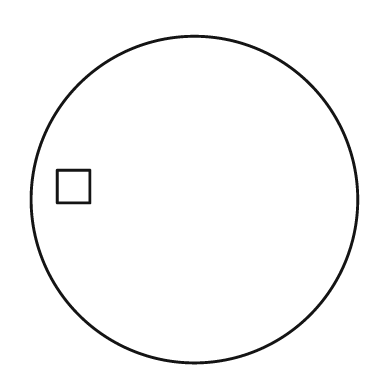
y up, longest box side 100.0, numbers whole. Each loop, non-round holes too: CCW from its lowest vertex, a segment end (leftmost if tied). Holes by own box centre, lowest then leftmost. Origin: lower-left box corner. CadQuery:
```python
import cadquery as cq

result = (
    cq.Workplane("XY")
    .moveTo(50.0, 50.0)
    .circle(50.0)
    .moveTo(8.0, 49.0)
    .lineTo(18.0, 49.0)
    .lineTo(18.0, 59.0)
    .lineTo(8.0, 59.0)
    .close()
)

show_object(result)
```